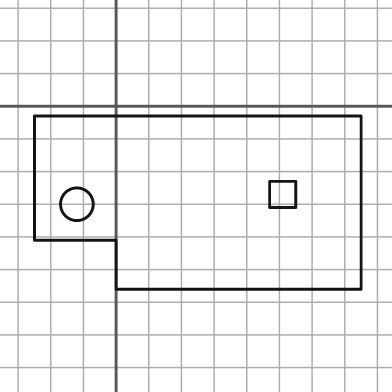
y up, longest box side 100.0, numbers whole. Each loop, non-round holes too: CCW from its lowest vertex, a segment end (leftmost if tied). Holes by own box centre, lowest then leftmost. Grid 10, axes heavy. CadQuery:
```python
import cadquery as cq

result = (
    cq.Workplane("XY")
    .moveTo(0.0, -56.0)
    .lineTo(75.0, -56.0)
    .lineTo(75.0, -3.0)
    .lineTo(-25.0, -3.0)
    .lineTo(-25.0, -41.0)
    .lineTo(0.0, -41.0)
    .close()
    .moveTo(-12.0, -30.0)
    .circle(5.0)
    .moveTo(47.0, -31.0)
    .lineTo(55.0, -31.0)
    .lineTo(55.0, -23.0)
    .lineTo(47.0, -23.0)
    .close()
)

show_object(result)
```